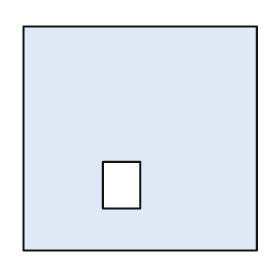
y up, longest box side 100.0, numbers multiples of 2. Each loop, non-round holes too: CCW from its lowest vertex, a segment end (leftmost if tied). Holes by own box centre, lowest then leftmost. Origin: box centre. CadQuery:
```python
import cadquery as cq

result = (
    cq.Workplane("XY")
    .moveTo(-50.0, -48.0)
    .lineTo(50.0, -48.0)
    .lineTo(50.0, 48.0)
    .lineTo(-50.0, 48.0)
    .close()
    .moveTo(-16.0, -30.0)
    .lineTo(0.0, -30.0)
    .lineTo(0.0, -10.0)
    .lineTo(-16.0, -10.0)
    .close()
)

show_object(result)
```